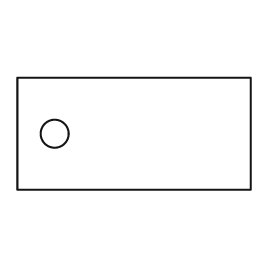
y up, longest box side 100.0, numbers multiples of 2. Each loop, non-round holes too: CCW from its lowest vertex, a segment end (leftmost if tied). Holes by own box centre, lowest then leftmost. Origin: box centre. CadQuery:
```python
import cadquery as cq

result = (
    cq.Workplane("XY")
    .moveTo(-50.0, -24.0)
    .lineTo(50.0, -24.0)
    .lineTo(50.0, 24.0)
    .lineTo(-50.0, 24.0)
    .close()
    .moveTo(-34.0, 0.0)
    .circle(6.0)
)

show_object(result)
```